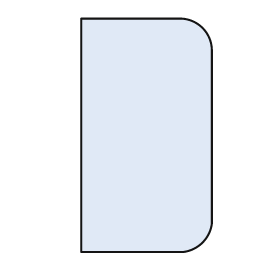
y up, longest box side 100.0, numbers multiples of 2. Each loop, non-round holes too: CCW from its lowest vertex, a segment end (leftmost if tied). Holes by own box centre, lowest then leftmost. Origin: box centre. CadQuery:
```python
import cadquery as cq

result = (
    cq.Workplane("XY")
    .moveTo(-28.0, -50.0)
    .lineTo(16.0, -50.0)
    .threePointArc((24.0, -46.0), (28.0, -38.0))
    .lineTo(28.0, 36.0)
    .threePointArc((24.0, 46.0), (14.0, 50.0))
    .lineTo(-28.0, 50.0)
    .close()
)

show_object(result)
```